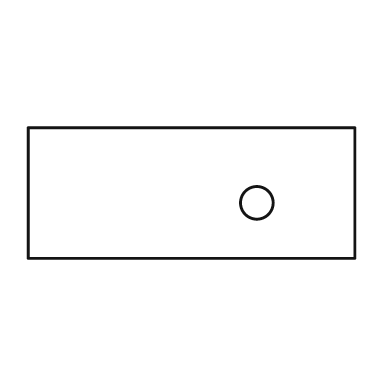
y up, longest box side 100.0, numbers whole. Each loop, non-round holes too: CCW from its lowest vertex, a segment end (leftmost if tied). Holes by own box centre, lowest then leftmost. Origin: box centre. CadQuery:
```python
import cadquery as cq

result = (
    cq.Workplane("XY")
    .moveTo(-50.0, -20.0)
    .lineTo(50.0, -20.0)
    .lineTo(50.0, 20.0)
    .lineTo(-50.0, 20.0)
    .close()
    .moveTo(20.0, -3.0)
    .circle(5.0)
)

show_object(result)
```